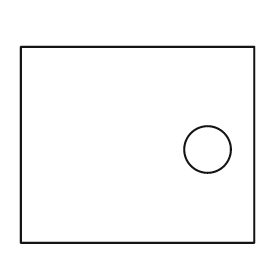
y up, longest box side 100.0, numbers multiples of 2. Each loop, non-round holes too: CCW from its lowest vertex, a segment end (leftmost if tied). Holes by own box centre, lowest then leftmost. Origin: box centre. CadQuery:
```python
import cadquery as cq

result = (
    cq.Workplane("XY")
    .moveTo(-50.0, -42.0)
    .lineTo(50.0, -42.0)
    .lineTo(50.0, 42.0)
    .lineTo(-50.0, 42.0)
    .close()
    .moveTo(30.0, -2.0)
    .circle(10.0)
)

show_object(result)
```